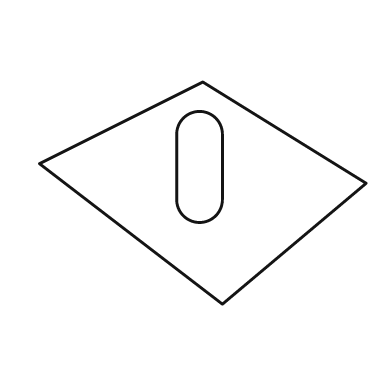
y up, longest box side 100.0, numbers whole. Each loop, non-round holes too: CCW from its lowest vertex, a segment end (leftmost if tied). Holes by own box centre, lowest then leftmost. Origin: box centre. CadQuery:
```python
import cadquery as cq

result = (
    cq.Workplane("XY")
    .moveTo(6.0, -34.0)
    .lineTo(50.0, 3.0)
    .lineTo(0.0, 34.0)
    .lineTo(-50.0, 9.0)
    .close()
    .moveTo(-8.0, -2.0)
    .threePointArc((-1.0, -9.0), (6.0, -2.0))
    .lineTo(6.0, 18.0)
    .threePointArc((-1.0, 25.0), (-8.0, 18.0))
    .close()
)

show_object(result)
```